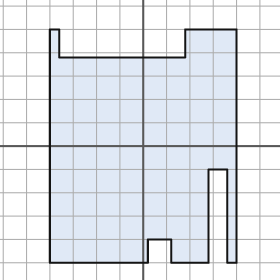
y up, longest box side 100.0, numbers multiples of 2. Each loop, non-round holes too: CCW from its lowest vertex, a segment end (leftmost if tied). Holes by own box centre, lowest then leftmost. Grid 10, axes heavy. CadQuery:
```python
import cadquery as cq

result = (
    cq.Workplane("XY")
    .moveTo(-40.0, -50.0)
    .lineTo(2.0, -50.0)
    .lineTo(2.0, -40.0)
    .lineTo(12.0, -40.0)
    .lineTo(12.0, -50.0)
    .lineTo(28.0, -50.0)
    .lineTo(28.0, -10.0)
    .lineTo(36.0, -10.0)
    .lineTo(36.0, -50.0)
    .lineTo(40.0, -50.0)
    .lineTo(40.0, 50.0)
    .lineTo(18.0, 50.0)
    .lineTo(18.0, 38.0)
    .lineTo(-36.0, 38.0)
    .lineTo(-36.0, 50.0)
    .lineTo(-40.0, 50.0)
    .close()
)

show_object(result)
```